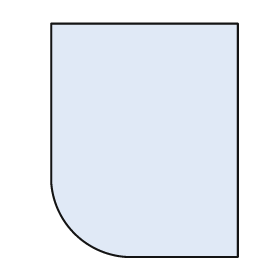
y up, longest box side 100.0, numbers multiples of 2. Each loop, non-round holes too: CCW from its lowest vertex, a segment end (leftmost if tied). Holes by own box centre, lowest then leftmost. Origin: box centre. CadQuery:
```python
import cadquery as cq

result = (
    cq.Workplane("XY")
    .moveTo(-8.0, -50.0)
    .lineTo(40.0, -50.0)
    .lineTo(40.0, 50.0)
    .lineTo(-40.0, 50.0)
    .lineTo(-40.0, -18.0)
    .threePointArc((-30.0, -40.0), (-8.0, -50.0))
    .close()
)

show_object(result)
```